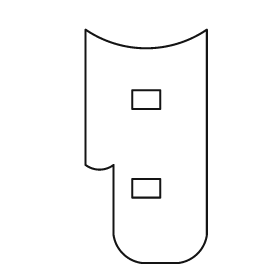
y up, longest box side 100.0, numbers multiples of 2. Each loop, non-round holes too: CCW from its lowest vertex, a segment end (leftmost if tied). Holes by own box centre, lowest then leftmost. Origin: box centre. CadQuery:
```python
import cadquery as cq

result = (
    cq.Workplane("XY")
    .moveTo(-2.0, -50.0)
    .lineTo(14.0, -50.0)
    .threePointArc((22.0, -46.0), (26.0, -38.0))
    .lineTo(26.0, 50.0)
    .threePointArc((0.0, 42.0), (-26.0, 50.0))
    .lineTo(-26.0, -8.0)
    .threePointArc((-20.0, -10.0), (-14.0, -8.0))
    .lineTo(-14.0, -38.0)
    .threePointArc((-10.0, -46.0), (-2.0, -50.0))
    .close()
    .moveTo(-6.0, -22.0)
    .lineTo(6.0, -22.0)
    .lineTo(6.0, -14.0)
    .lineTo(-6.0, -14.0)
    .close()
    .moveTo(-6.0, 16.0)
    .lineTo(6.0, 16.0)
    .lineTo(6.0, 24.0)
    .lineTo(-6.0, 24.0)
    .close()
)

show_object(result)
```